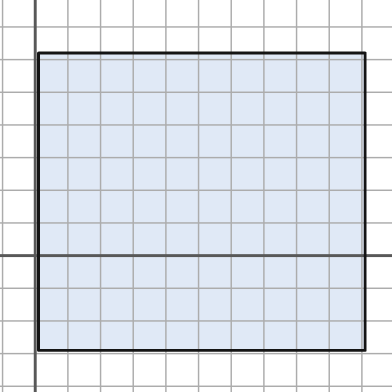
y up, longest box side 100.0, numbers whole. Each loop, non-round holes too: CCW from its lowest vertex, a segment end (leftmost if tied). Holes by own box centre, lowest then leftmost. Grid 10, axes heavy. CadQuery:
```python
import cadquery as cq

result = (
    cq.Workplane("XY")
    .moveTo(1.0, -29.0)
    .lineTo(101.0, -29.0)
    .lineTo(101.0, 62.0)
    .lineTo(1.0, 62.0)
    .close()
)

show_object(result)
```